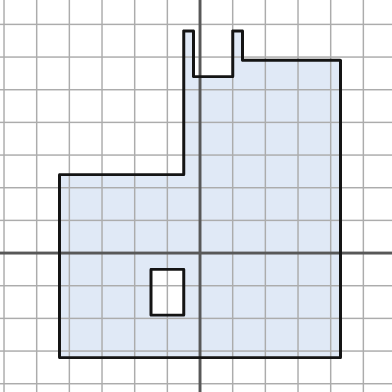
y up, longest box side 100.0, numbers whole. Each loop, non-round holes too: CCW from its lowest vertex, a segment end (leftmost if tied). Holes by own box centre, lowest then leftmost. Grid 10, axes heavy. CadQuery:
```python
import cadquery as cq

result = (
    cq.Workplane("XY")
    .moveTo(-43.0, -32.0)
    .lineTo(43.0, -32.0)
    .lineTo(43.0, 59.0)
    .lineTo(13.0, 59.0)
    .lineTo(13.0, 68.0)
    .lineTo(10.0, 68.0)
    .lineTo(10.0, 54.0)
    .lineTo(-2.0, 54.0)
    .lineTo(-2.0, 68.0)
    .lineTo(-5.0, 68.0)
    .lineTo(-5.0, 24.0)
    .lineTo(-43.0, 24.0)
    .close()
    .moveTo(-15.0, -19.0)
    .lineTo(-5.0, -19.0)
    .lineTo(-5.0, -5.0)
    .lineTo(-15.0, -5.0)
    .close()
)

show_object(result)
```